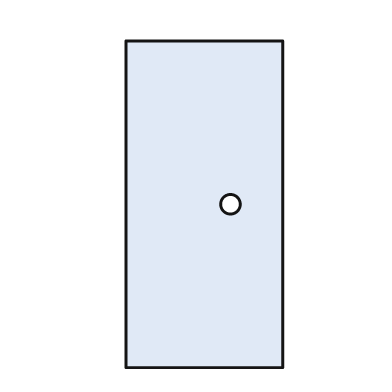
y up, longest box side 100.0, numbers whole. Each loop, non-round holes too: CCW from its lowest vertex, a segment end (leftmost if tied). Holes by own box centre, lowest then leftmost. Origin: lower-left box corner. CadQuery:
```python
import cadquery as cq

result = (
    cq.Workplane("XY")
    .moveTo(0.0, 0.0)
    .lineTo(48.0, 0.0)
    .lineTo(48.0, 100.0)
    .lineTo(0.0, 100.0)
    .close()
    .moveTo(32.0, 50.0)
    .circle(3.0)
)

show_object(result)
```